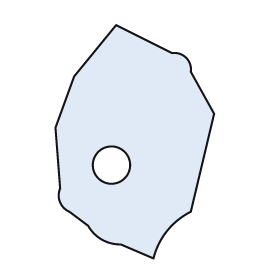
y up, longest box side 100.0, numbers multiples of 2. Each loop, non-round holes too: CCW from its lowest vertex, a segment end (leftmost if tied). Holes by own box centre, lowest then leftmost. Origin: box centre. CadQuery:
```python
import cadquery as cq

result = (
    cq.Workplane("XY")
    .moveTo(8.0, -50.0)
    .threePointArc((14.0, -38.0), (24.0, -30.0))
    .lineTo(34.0, 12.0)
    .lineTo(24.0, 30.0)
    .threePointArc((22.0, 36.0), (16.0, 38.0))
    .lineTo(-8.0, 50.0)
    .lineTo(-26.0, 28.0)
    .lineTo(-34.0, 6.0)
    .lineTo(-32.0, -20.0)
    .threePointArc((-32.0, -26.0), (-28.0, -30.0))
    .lineTo(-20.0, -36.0)
    .threePointArc((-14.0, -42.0), (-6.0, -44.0))
    .close()
    .moveTo(-10.0, -10.0)
    .circle(8.0)
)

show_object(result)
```